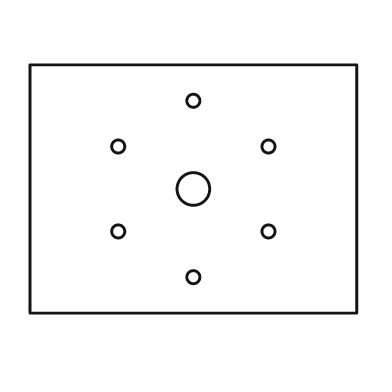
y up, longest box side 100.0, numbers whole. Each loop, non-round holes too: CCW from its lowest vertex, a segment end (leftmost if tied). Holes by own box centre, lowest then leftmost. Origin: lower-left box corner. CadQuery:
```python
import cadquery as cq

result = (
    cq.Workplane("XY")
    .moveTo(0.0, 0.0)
    .lineTo(100.0, 0.0)
    .lineTo(100.0, 76.0)
    .lineTo(0.0, 76.0)
    .close()
    .moveTo(50.0, 11.0)
    .circle(2.0)
    .moveTo(27.0, 25.0)
    .circle(2.0)
    .moveTo(73.0, 25.0)
    .circle(2.0)
    .moveTo(50.0, 38.0)
    .circle(5.0)
    .moveTo(27.0, 51.0)
    .circle(2.0)
    .moveTo(73.0, 51.0)
    .circle(2.0)
    .moveTo(50.0, 65.0)
    .circle(2.0)
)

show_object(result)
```